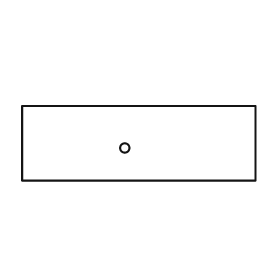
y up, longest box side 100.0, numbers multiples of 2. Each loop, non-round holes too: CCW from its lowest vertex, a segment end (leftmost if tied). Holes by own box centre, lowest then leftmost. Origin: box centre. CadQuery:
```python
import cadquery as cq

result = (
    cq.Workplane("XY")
    .moveTo(-50.0, -16.0)
    .lineTo(50.0, -16.0)
    .lineTo(50.0, 16.0)
    .lineTo(-50.0, 16.0)
    .close()
    .moveTo(-6.0, -2.0)
    .circle(2.0)
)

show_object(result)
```